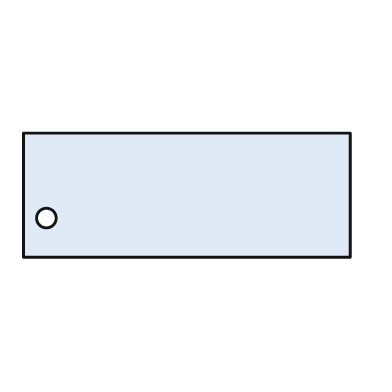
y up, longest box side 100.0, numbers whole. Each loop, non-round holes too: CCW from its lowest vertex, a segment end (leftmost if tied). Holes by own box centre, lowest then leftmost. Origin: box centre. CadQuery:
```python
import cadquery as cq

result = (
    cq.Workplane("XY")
    .moveTo(-50.0, -19.0)
    .lineTo(50.0, -19.0)
    .lineTo(50.0, 19.0)
    .lineTo(-50.0, 19.0)
    .close()
    .moveTo(-43.0, -7.0)
    .circle(3.0)
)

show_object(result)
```